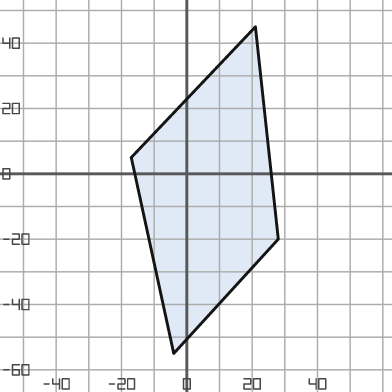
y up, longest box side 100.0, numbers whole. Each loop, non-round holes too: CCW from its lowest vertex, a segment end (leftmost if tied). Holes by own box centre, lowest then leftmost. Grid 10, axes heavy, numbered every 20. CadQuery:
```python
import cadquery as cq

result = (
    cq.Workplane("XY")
    .moveTo(-4.0, -55.0)
    .lineTo(28.0, -20.0)
    .lineTo(21.0, 45.0)
    .lineTo(-17.0, 5.0)
    .close()
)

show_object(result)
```